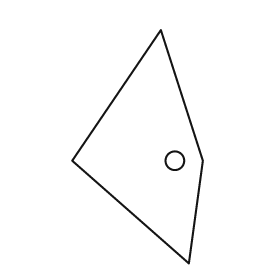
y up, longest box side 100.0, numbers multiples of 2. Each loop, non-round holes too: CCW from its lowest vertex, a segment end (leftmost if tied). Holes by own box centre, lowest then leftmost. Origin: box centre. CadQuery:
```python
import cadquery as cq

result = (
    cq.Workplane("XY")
    .moveTo(22.0, -50.0)
    .lineTo(28.0, -6.0)
    .lineTo(10.0, 50.0)
    .lineTo(-28.0, -6.0)
    .close()
    .moveTo(16.0, -6.0)
    .circle(4.0)
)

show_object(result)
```